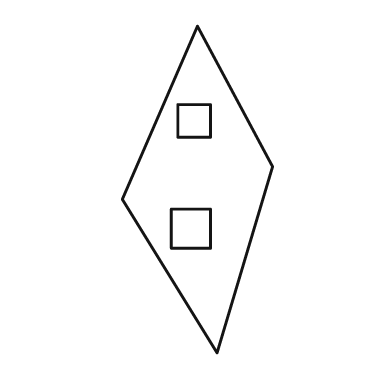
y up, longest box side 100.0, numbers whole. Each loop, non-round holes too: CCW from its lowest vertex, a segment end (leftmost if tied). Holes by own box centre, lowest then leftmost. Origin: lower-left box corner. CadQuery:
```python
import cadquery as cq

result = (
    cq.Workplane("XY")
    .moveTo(29.0, 0.0)
    .lineTo(46.0, 57.0)
    .lineTo(23.0, 100.0)
    .lineTo(0.0, 47.0)
    .close()
    .moveTo(15.0, 32.0)
    .lineTo(27.0, 32.0)
    .lineTo(27.0, 44.0)
    .lineTo(15.0, 44.0)
    .close()
    .moveTo(17.0, 66.0)
    .lineTo(27.0, 66.0)
    .lineTo(27.0, 76.0)
    .lineTo(17.0, 76.0)
    .close()
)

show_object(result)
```